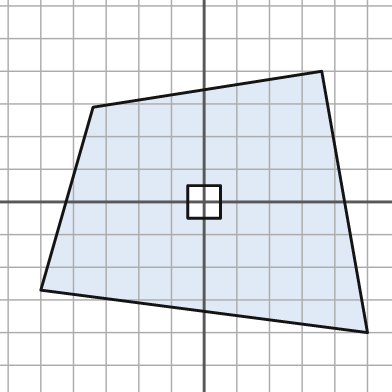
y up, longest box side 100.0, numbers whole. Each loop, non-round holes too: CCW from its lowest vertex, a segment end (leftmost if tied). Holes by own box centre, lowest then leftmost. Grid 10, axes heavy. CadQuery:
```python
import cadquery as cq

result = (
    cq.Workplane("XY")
    .moveTo(50.0, -40.0)
    .lineTo(36.0, 40.0)
    .lineTo(-34.0, 29.0)
    .lineTo(-50.0, -27.0)
    .close()
    .moveTo(-5.0, -5.0)
    .lineTo(5.0, -5.0)
    .lineTo(5.0, 5.0)
    .lineTo(-5.0, 5.0)
    .close()
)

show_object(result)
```